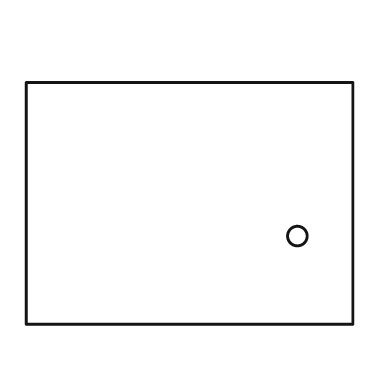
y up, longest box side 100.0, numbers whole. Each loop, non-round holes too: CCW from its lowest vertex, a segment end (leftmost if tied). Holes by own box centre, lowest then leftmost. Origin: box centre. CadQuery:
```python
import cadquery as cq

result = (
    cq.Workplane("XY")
    .moveTo(-50.0, -37.0)
    .lineTo(50.0, -37.0)
    .lineTo(50.0, 37.0)
    .lineTo(-50.0, 37.0)
    .close()
    .moveTo(33.0, -10.0)
    .circle(3.0)
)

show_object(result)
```